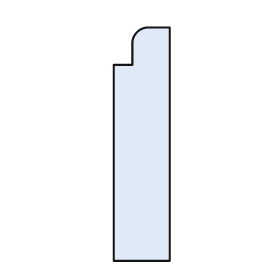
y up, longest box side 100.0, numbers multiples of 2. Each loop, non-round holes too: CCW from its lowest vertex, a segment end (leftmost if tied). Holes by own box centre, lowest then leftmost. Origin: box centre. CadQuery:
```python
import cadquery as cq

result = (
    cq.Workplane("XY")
    .moveTo(-12.0, -50.0)
    .lineTo(12.0, -50.0)
    .lineTo(12.0, 50.0)
    .lineTo(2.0, 50.0)
    .threePointArc((-2.0, 48.0), (-4.0, 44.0))
    .lineTo(-4.0, 34.0)
    .lineTo(-12.0, 34.0)
    .close()
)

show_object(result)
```